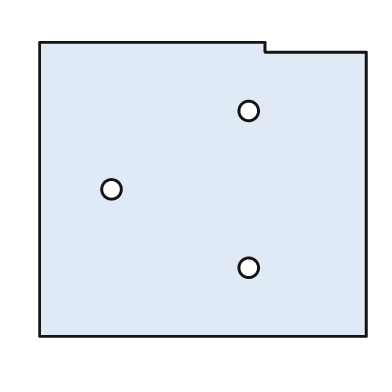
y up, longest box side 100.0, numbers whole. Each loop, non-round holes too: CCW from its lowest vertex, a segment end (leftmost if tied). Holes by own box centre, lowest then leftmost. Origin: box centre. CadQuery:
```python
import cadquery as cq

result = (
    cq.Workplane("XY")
    .moveTo(-50.0, -45.0)
    .lineTo(50.0, -45.0)
    .lineTo(50.0, 42.0)
    .lineTo(19.0, 42.0)
    .lineTo(19.0, 45.0)
    .lineTo(-50.0, 45.0)
    .close()
    .moveTo(14.0, -24.0)
    .circle(3.0)
    .moveTo(-28.0, 0.0)
    .circle(3.0)
    .moveTo(14.0, 24.0)
    .circle(3.0)
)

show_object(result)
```